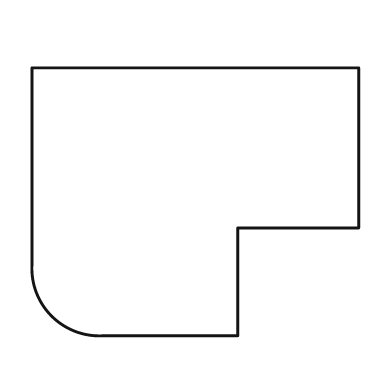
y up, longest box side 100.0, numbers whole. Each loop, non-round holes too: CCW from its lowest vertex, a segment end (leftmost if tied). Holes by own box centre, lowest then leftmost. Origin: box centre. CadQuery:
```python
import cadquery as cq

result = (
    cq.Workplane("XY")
    .moveTo(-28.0, -41.0)
    .lineTo(13.0, -41.0)
    .lineTo(13.0, -8.0)
    .lineTo(50.0, -8.0)
    .lineTo(50.0, 41.0)
    .lineTo(-50.0, 41.0)
    .lineTo(-50.0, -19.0)
    .threePointArc((-44.0, -35.0), (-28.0, -41.0))
    .close()
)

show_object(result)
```